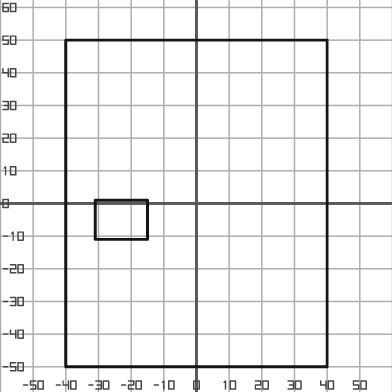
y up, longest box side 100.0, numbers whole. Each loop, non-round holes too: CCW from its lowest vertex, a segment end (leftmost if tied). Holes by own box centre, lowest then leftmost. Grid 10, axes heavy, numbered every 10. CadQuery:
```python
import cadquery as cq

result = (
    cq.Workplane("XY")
    .moveTo(-40.0, -50.0)
    .lineTo(40.0, -50.0)
    .lineTo(40.0, 50.0)
    .lineTo(-40.0, 50.0)
    .close()
    .moveTo(-31.0, -11.0)
    .lineTo(-15.0, -11.0)
    .lineTo(-15.0, 1.0)
    .lineTo(-31.0, 1.0)
    .close()
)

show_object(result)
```